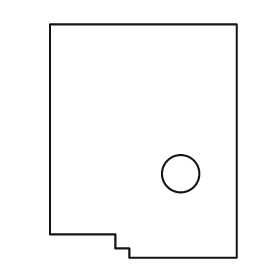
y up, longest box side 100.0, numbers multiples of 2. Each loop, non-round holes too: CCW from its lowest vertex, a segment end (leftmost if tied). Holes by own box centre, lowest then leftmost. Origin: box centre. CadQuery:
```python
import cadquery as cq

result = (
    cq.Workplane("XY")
    .moveTo(-6.0, -50.0)
    .lineTo(40.0, -50.0)
    .lineTo(40.0, 50.0)
    .lineTo(-40.0, 50.0)
    .lineTo(-40.0, -40.0)
    .lineTo(-12.0, -40.0)
    .lineTo(-12.0, -46.0)
    .lineTo(-6.0, -46.0)
    .close()
    .moveTo(16.0, -14.0)
    .circle(8.0)
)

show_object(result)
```